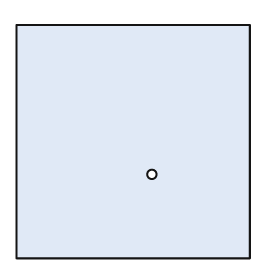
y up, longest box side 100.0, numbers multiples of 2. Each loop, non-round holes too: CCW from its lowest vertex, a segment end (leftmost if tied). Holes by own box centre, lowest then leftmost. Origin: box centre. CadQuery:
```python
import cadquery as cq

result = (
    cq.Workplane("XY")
    .moveTo(-50.0, -50.0)
    .lineTo(50.0, -50.0)
    .lineTo(50.0, 50.0)
    .lineTo(-50.0, 50.0)
    .close()
    .moveTo(8.0, -14.0)
    .circle(2.0)
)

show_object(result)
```